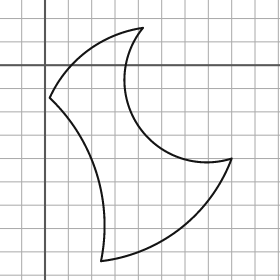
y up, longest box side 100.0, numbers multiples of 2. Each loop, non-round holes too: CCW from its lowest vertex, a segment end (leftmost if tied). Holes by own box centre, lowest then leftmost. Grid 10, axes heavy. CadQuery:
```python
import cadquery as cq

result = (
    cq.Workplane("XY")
    .moveTo(24.0, -84.0)
    .threePointArc((58.0, -70.0), (80.0, -40.0))
    .threePointArc((40.0, -26.0), (42.0, 16.0))
    .threePointArc((18.0, 6.0), (2.0, -14.0))
    .threePointArc((22.0, -46.0), (24.0, -84.0))
    .close()
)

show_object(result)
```